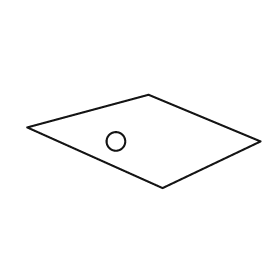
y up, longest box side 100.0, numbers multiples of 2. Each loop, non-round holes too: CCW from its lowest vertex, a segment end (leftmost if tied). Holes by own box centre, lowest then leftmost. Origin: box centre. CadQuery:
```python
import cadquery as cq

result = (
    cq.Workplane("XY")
    .moveTo(8.0, -20.0)
    .lineTo(50.0, 0.0)
    .lineTo(2.0, 20.0)
    .lineTo(-50.0, 6.0)
    .close()
    .moveTo(-12.0, 0.0)
    .circle(4.0)
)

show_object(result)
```